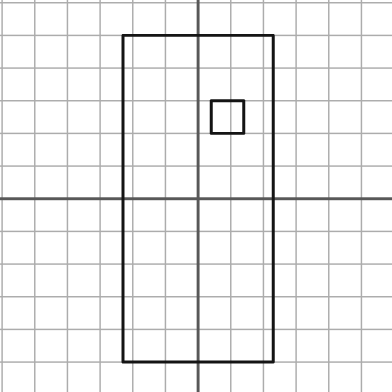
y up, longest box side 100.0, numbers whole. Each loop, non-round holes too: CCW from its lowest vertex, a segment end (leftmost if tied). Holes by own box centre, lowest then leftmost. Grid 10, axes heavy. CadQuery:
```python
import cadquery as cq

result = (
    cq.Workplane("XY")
    .moveTo(-23.0, -50.0)
    .lineTo(23.0, -50.0)
    .lineTo(23.0, 50.0)
    .lineTo(-23.0, 50.0)
    .close()
    .moveTo(4.0, 20.0)
    .lineTo(14.0, 20.0)
    .lineTo(14.0, 30.0)
    .lineTo(4.0, 30.0)
    .close()
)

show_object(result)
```